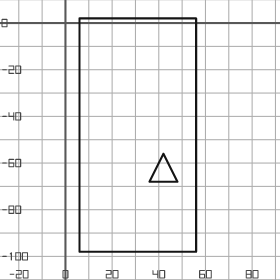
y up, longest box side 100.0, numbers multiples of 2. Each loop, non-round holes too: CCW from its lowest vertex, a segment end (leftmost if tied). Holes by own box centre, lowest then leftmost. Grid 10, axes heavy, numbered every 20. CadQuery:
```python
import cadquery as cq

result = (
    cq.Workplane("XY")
    .moveTo(6.0, -98.0)
    .lineTo(56.0, -98.0)
    .lineTo(56.0, 2.0)
    .lineTo(6.0, 2.0)
    .close()
    .moveTo(36.0, -68.0)
    .lineTo(48.0, -68.0)
    .lineTo(42.0, -56.0)
    .close()
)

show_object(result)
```